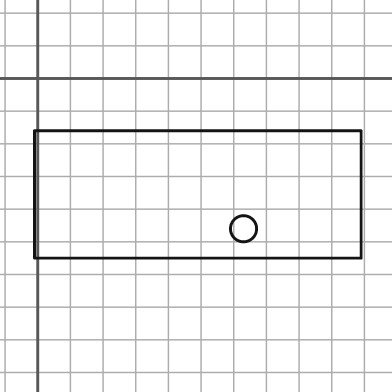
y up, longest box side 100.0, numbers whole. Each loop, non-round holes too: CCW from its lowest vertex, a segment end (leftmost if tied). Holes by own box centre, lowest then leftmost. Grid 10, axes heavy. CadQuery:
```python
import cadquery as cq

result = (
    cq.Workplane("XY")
    .moveTo(-1.0, -55.0)
    .lineTo(99.0, -55.0)
    .lineTo(99.0, -16.0)
    .lineTo(-1.0, -16.0)
    .close()
    .moveTo(63.0, -46.0)
    .circle(4.0)
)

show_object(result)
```